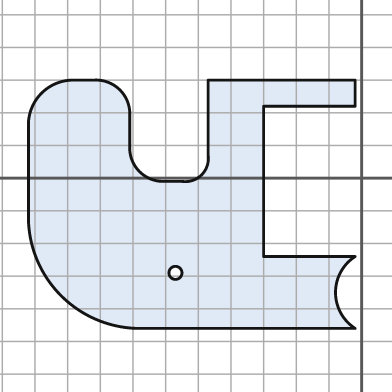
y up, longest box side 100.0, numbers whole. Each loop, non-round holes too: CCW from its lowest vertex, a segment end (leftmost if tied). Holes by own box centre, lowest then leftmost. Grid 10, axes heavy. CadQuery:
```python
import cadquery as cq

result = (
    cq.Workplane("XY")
    .moveTo(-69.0, -46.0)
    .lineTo(-2.0, -46.0)
    .threePointArc((-8.0, -35.0), (-2.0, -24.0))
    .lineTo(-30.0, -24.0)
    .lineTo(-30.0, 22.0)
    .lineTo(-2.0, 22.0)
    .lineTo(-2.0, 30.0)
    .lineTo(-47.0, 30.0)
    .lineTo(-47.0, 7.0)
    .threePointArc((-49.0, 1.0), (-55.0, -1.0))
    .lineTo(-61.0, -1.0)
    .threePointArc((-68.0, 2.0), (-71.0, 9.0))
    .lineTo(-71.0, 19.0)
    .threePointArc((-74.0, 27.0), (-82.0, 30.0))
    .lineTo(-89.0, 30.0)
    .threePointArc((-98.0, 26.0), (-102.0, 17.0))
    .lineTo(-102.0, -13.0)
    .threePointArc((-92.0, -36.0), (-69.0, -46.0))
    .close()
    .moveTo(-57.0, -29.0)
    .circle(2.0)
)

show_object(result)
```